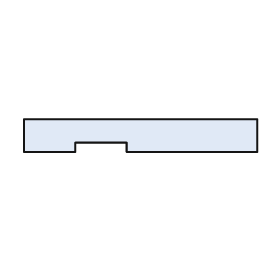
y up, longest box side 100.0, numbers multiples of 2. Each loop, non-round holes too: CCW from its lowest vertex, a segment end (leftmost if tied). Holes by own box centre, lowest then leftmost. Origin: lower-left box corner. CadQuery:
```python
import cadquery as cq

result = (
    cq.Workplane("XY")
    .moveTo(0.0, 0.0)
    .lineTo(22.0, 0.0)
    .lineTo(22.0, 4.0)
    .lineTo(44.0, 4.0)
    .lineTo(44.0, 0.0)
    .lineTo(100.0, 0.0)
    .lineTo(100.0, 14.0)
    .lineTo(0.0, 14.0)
    .close()
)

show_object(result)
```